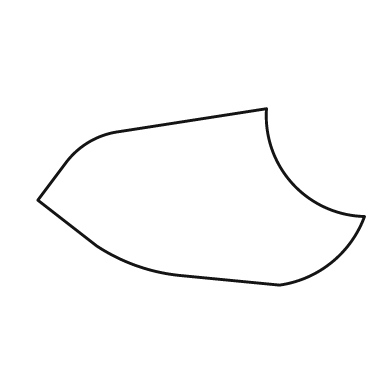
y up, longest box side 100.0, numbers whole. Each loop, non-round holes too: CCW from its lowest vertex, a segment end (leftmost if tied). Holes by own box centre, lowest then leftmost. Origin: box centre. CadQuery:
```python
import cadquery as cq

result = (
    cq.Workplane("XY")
    .moveTo(24.0, -27.0)
    .threePointArc((40.0, -20.0), (50.0, -6.0))
    .threePointArc((28.0, 4.0), (20.0, 27.0))
    .lineTo(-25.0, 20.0)
    .threePointArc((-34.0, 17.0), (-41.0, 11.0))
    .lineTo(-50.0, -1.0)
    .lineTo(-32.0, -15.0)
    .threePointArc((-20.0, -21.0), (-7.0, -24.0))
    .close()
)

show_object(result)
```